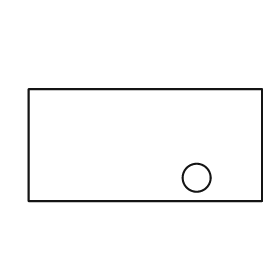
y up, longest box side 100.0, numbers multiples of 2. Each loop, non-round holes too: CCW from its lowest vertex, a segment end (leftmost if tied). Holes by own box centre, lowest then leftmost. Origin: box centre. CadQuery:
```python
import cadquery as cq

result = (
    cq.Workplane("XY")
    .moveTo(-50.0, -24.0)
    .lineTo(50.0, -24.0)
    .lineTo(50.0, 24.0)
    .lineTo(-50.0, 24.0)
    .close()
    .moveTo(22.0, -14.0)
    .circle(6.0)
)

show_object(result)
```